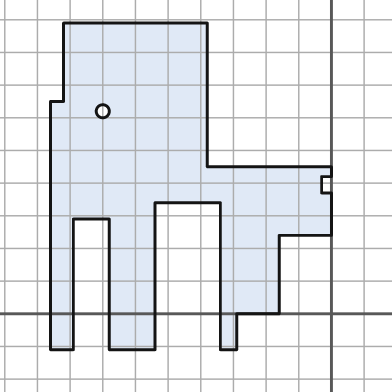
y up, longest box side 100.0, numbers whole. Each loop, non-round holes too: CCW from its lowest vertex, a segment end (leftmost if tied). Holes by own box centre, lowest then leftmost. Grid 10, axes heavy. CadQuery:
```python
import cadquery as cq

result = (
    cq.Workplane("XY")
    .moveTo(-86.0, -11.0)
    .lineTo(-79.0, -11.0)
    .lineTo(-79.0, 29.0)
    .lineTo(-68.0, 29.0)
    .lineTo(-68.0, -11.0)
    .lineTo(-54.0, -11.0)
    .lineTo(-54.0, 34.0)
    .lineTo(-34.0, 34.0)
    .lineTo(-34.0, -11.0)
    .lineTo(-29.0, -11.0)
    .lineTo(-29.0, 0.0)
    .lineTo(-16.0, 0.0)
    .lineTo(-16.0, 24.0)
    .lineTo(0.0, 24.0)
    .lineTo(0.0, 37.0)
    .lineTo(-3.0, 37.0)
    .lineTo(-3.0, 42.0)
    .lineTo(0.0, 42.0)
    .lineTo(0.0, 45.0)
    .lineTo(-38.0, 45.0)
    .lineTo(-38.0, 89.0)
    .lineTo(-82.0, 89.0)
    .lineTo(-82.0, 65.0)
    .lineTo(-86.0, 65.0)
    .close()
    .moveTo(-70.0, 62.0)
    .circle(2.0)
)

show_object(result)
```